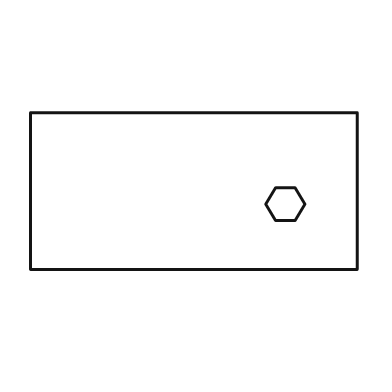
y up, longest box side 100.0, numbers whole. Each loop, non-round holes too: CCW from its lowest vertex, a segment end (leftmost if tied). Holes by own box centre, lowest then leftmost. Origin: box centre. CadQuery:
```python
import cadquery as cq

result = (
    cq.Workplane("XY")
    .moveTo(-50.0, -24.0)
    .lineTo(50.0, -24.0)
    .lineTo(50.0, 24.0)
    .lineTo(-50.0, 24.0)
    .close()
    .moveTo(25.0, -9.0)
    .lineTo(31.0, -9.0)
    .lineTo(34.0, -4.0)
    .lineTo(31.0, 1.0)
    .lineTo(25.0, 1.0)
    .lineTo(22.0, -4.0)
    .close()
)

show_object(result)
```